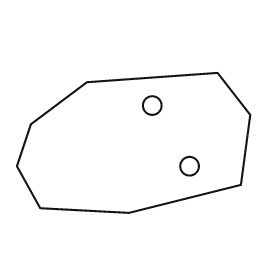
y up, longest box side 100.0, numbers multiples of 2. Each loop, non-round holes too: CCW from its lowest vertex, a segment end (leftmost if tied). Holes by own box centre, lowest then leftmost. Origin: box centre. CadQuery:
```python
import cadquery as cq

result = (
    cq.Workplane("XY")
    .moveTo(-2.0, -30.0)
    .lineTo(46.0, -18.0)
    .lineTo(50.0, 12.0)
    .lineTo(36.0, 30.0)
    .lineTo(-20.0, 26.0)
    .lineTo(-44.0, 8.0)
    .lineTo(-50.0, -10.0)
    .lineTo(-40.0, -28.0)
    .close()
    .moveTo(24.0, -10.0)
    .circle(4.0)
    .moveTo(8.0, 16.0)
    .circle(4.0)
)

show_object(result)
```